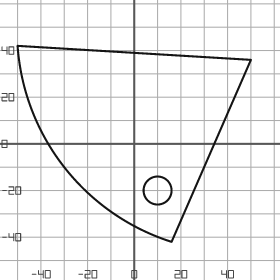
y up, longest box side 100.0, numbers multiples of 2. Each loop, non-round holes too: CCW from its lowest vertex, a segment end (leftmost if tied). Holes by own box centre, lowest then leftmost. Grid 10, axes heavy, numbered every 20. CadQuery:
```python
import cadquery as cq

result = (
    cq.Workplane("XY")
    .moveTo(16.0, -42.0)
    .lineTo(50.0, 36.0)
    .lineTo(-50.0, 42.0)
    .threePointArc((-30.0, -10.0), (16.0, -42.0))
    .close()
    .moveTo(10.0, -20.0)
    .circle(6.0)
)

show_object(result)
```